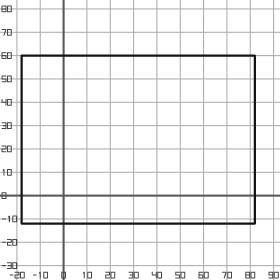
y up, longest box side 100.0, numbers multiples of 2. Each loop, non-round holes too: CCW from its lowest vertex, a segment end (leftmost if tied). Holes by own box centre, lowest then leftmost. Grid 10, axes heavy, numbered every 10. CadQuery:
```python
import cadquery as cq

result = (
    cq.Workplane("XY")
    .moveTo(-18.0, -12.0)
    .lineTo(82.0, -12.0)
    .lineTo(82.0, 60.0)
    .lineTo(-18.0, 60.0)
    .close()
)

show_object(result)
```